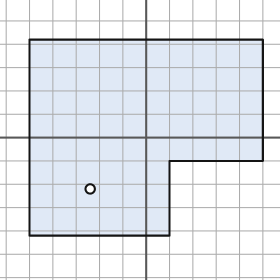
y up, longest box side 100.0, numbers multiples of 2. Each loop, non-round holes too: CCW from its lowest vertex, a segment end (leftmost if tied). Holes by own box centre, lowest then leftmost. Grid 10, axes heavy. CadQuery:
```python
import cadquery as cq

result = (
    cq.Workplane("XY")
    .moveTo(-50.0, -42.0)
    .lineTo(10.0, -42.0)
    .lineTo(10.0, -10.0)
    .lineTo(50.0, -10.0)
    .lineTo(50.0, 42.0)
    .lineTo(-50.0, 42.0)
    .close()
    .moveTo(-24.0, -22.0)
    .circle(2.0)
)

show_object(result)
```